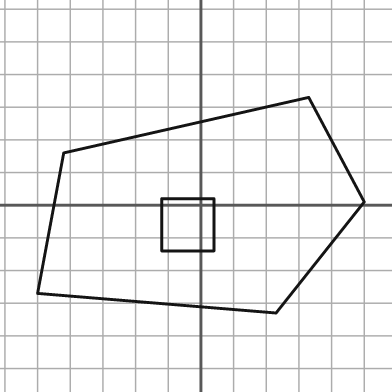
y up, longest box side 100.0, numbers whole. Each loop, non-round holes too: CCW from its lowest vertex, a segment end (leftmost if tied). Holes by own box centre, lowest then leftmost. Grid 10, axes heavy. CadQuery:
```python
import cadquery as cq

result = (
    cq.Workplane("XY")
    .moveTo(23.0, -33.0)
    .lineTo(50.0, 1.0)
    .lineTo(33.0, 33.0)
    .lineTo(-42.0, 16.0)
    .lineTo(-50.0, -27.0)
    .close()
    .moveTo(-12.0, -14.0)
    .lineTo(4.0, -14.0)
    .lineTo(4.0, 2.0)
    .lineTo(-12.0, 2.0)
    .close()
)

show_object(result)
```